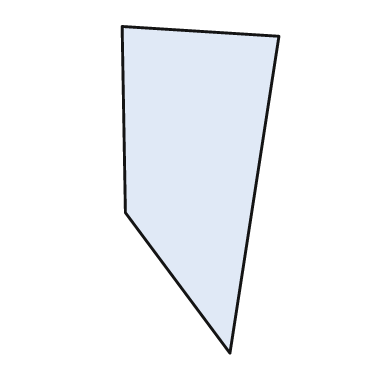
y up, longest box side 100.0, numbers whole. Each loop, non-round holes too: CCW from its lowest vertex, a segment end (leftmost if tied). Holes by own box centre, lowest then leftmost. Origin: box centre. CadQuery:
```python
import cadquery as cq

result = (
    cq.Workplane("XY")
    .moveTo(9.0, -50.0)
    .lineTo(24.0, 47.0)
    .lineTo(-24.0, 50.0)
    .lineTo(-23.0, -7.0)
    .close()
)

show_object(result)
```